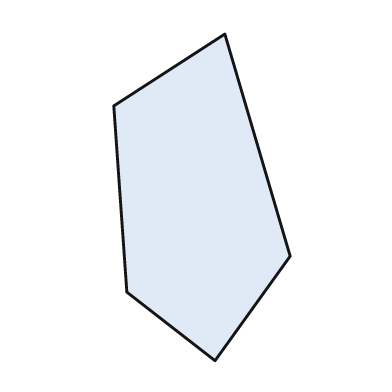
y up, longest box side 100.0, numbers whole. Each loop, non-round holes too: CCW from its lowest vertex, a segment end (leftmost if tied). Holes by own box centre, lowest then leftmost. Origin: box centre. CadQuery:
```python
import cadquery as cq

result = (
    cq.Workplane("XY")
    .moveTo(4.0, -50.0)
    .lineTo(27.0, -18.0)
    .lineTo(7.0, 50.0)
    .lineTo(-27.0, 28.0)
    .lineTo(-23.0, -29.0)
    .close()
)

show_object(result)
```